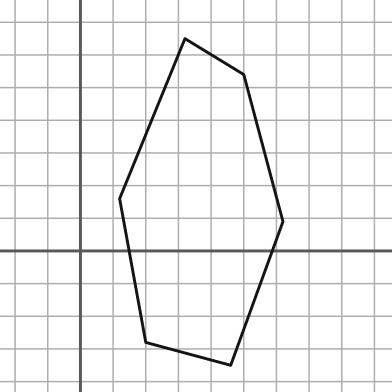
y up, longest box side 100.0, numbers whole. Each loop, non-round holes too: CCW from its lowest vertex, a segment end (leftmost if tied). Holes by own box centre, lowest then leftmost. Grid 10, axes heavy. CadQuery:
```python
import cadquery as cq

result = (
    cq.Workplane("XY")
    .moveTo(46.0, -35.0)
    .lineTo(62.0, 9.0)
    .lineTo(50.0, 54.0)
    .lineTo(32.0, 65.0)
    .lineTo(12.0, 16.0)
    .lineTo(20.0, -28.0)
    .close()
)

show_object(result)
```